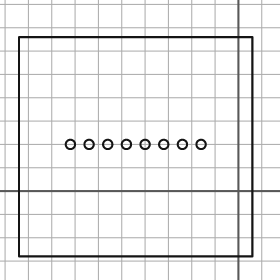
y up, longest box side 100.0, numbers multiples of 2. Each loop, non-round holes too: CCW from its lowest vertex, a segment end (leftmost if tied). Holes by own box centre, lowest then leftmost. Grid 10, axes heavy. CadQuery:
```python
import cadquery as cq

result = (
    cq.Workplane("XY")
    .moveTo(-94.0, -28.0)
    .lineTo(6.0, -28.0)
    .lineTo(6.0, 66.0)
    .lineTo(-94.0, 66.0)
    .close()
    .moveTo(-72.0, 20.0)
    .circle(2.0)
    .moveTo(-64.0, 20.0)
    .circle(2.0)
    .moveTo(-56.0, 20.0)
    .circle(2.0)
    .moveTo(-48.0, 20.0)
    .circle(2.0)
    .moveTo(-40.0, 20.0)
    .circle(2.0)
    .moveTo(-32.0, 20.0)
    .circle(2.0)
    .moveTo(-24.0, 20.0)
    .circle(2.0)
    .moveTo(-16.0, 20.0)
    .circle(2.0)
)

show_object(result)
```